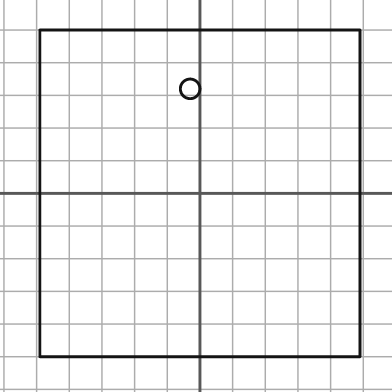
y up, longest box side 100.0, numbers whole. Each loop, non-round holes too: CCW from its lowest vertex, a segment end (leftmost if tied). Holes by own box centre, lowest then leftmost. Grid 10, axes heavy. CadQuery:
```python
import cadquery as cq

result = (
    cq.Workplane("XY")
    .moveTo(-49.0, -50.0)
    .lineTo(49.0, -50.0)
    .lineTo(49.0, 50.0)
    .lineTo(-49.0, 50.0)
    .close()
    .moveTo(-3.0, 32.0)
    .circle(3.0)
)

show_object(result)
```